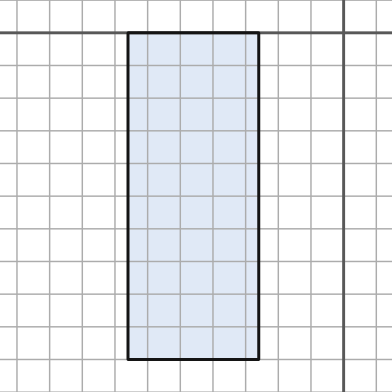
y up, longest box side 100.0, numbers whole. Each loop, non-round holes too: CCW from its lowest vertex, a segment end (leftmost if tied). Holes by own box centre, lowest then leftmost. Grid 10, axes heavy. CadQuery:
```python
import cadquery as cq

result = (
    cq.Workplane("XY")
    .moveTo(-66.0, -100.0)
    .lineTo(-26.0, -100.0)
    .lineTo(-26.0, 0.0)
    .lineTo(-66.0, 0.0)
    .close()
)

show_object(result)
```